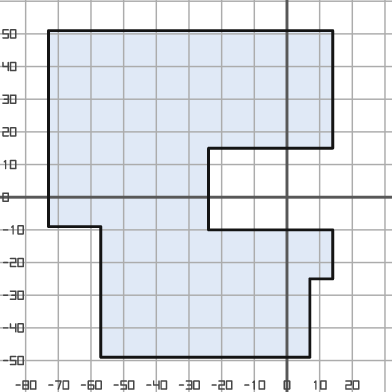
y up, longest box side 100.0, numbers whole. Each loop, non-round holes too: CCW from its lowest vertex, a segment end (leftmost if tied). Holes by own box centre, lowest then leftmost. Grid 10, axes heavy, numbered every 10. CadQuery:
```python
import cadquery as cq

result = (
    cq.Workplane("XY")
    .moveTo(-57.0, -49.0)
    .lineTo(7.0, -49.0)
    .lineTo(7.0, -25.0)
    .lineTo(14.0, -25.0)
    .lineTo(14.0, -10.0)
    .lineTo(-24.0, -10.0)
    .lineTo(-24.0, 15.0)
    .lineTo(14.0, 15.0)
    .lineTo(14.0, 51.0)
    .lineTo(-73.0, 51.0)
    .lineTo(-73.0, -9.0)
    .lineTo(-57.0, -9.0)
    .close()
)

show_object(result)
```